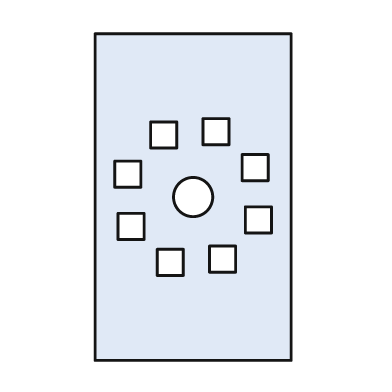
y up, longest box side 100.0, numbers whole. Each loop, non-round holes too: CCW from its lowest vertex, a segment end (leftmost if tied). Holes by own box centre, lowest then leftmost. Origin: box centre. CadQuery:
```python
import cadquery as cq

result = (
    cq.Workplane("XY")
    .moveTo(-30.0, -50.0)
    .lineTo(30.0, -50.0)
    .lineTo(30.0, 50.0)
    .lineTo(-30.0, 50.0)
    .close()
    .moveTo(-11.0, -24.0)
    .lineTo(-3.0, -24.0)
    .lineTo(-3.0, -16.0)
    .lineTo(-11.0, -16.0)
    .close()
    .moveTo(5.0, -23.0)
    .lineTo(13.0, -23.0)
    .lineTo(13.0, -15.0)
    .lineTo(5.0, -15.0)
    .close()
    .moveTo(-23.0, -13.0)
    .lineTo(-15.0, -13.0)
    .lineTo(-15.0, -5.0)
    .lineTo(-23.0, -5.0)
    .close()
    .moveTo(16.0, -11.0)
    .lineTo(24.0, -11.0)
    .lineTo(24.0, -3.0)
    .lineTo(16.0, -3.0)
    .close()
    .moveTo(0.0, 0.0)
    .circle(6.0)
    .moveTo(-24.0, 3.0)
    .lineTo(-16.0, 3.0)
    .lineTo(-16.0, 11.0)
    .lineTo(-24.0, 11.0)
    .close()
    .moveTo(15.0, 5.0)
    .lineTo(23.0, 5.0)
    .lineTo(23.0, 13.0)
    .lineTo(15.0, 13.0)
    .close()
    .moveTo(-13.0, 15.0)
    .lineTo(-5.0, 15.0)
    .lineTo(-5.0, 23.0)
    .lineTo(-13.0, 23.0)
    .close()
    .moveTo(3.0, 16.0)
    .lineTo(11.0, 16.0)
    .lineTo(11.0, 24.0)
    .lineTo(3.0, 24.0)
    .close()
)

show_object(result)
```